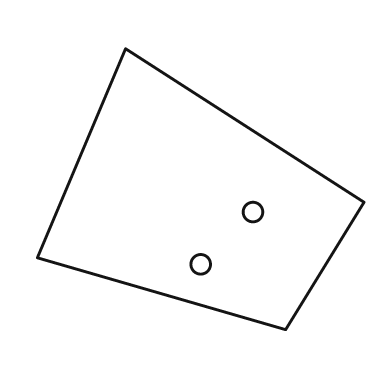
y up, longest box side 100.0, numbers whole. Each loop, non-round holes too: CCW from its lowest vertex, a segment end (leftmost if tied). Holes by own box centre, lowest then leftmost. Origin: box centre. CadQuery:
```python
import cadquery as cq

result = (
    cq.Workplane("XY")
    .moveTo(26.0, -43.0)
    .lineTo(50.0, -4.0)
    .lineTo(-23.0, 43.0)
    .lineTo(-50.0, -21.0)
    .close()
    .moveTo(0.0, -23.0)
    .circle(3.0)
    .moveTo(16.0, -7.0)
    .circle(3.0)
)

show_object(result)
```